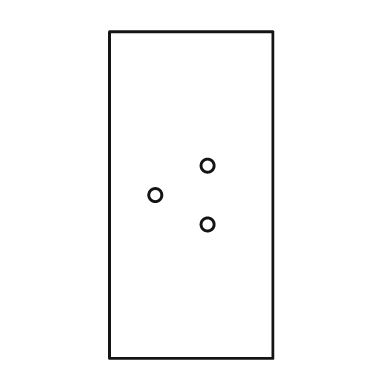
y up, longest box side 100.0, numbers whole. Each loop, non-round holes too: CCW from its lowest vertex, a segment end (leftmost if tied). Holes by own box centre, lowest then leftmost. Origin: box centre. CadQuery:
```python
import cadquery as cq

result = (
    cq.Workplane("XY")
    .moveTo(-25.0, -50.0)
    .lineTo(25.0, -50.0)
    .lineTo(25.0, 50.0)
    .lineTo(-25.0, 50.0)
    .close()
    .moveTo(5.0, -9.0)
    .circle(2.0)
    .moveTo(-11.0, 0.0)
    .circle(2.0)
    .moveTo(5.0, 9.0)
    .circle(2.0)
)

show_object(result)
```